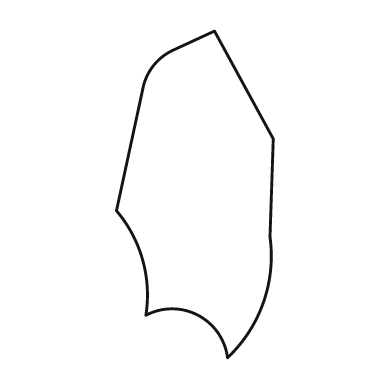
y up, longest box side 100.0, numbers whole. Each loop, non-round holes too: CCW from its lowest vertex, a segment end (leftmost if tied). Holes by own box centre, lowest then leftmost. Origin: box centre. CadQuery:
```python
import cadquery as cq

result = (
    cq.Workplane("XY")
    .moveTo(10.0, -50.0)
    .threePointArc((21.0, -33.0), (23.0, -13.0))
    .lineTo(24.0, 17.0)
    .lineTo(6.0, 50.0)
    .lineTo(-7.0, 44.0)
    .threePointArc((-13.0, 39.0), (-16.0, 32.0))
    .lineTo(-24.0, -5.0)
    .threePointArc((-16.0, -20.0), (-15.0, -37.0))
    .threePointArc((1.0, -37.0), (10.0, -50.0))
    .close()
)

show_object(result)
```